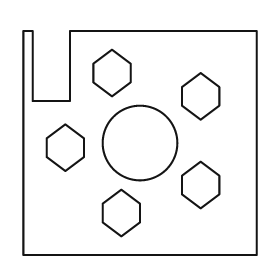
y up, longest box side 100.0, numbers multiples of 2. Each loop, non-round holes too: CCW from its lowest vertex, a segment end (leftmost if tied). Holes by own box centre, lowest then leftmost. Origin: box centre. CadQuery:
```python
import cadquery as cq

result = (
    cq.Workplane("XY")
    .moveTo(-50.0, -48.0)
    .lineTo(50.0, -48.0)
    .lineTo(50.0, 48.0)
    .lineTo(-30.0, 48.0)
    .lineTo(-30.0, 18.0)
    .lineTo(-46.0, 18.0)
    .lineTo(-46.0, 48.0)
    .lineTo(-50.0, 48.0)
    .close()
    .moveTo(-8.0, -40.0)
    .lineTo(0.0, -34.0)
    .lineTo(0.0, -26.0)
    .lineTo(-8.0, -20.0)
    .lineTo(-16.0, -26.0)
    .lineTo(-16.0, -34.0)
    .close()
    .moveTo(26.0, -28.0)
    .lineTo(34.0, -22.0)
    .lineTo(34.0, -14.0)
    .lineTo(26.0, -8.0)
    .lineTo(18.0, -14.0)
    .lineTo(18.0, -22.0)
    .close()
    .moveTo(-32.0, -12.0)
    .lineTo(-24.0, -6.0)
    .lineTo(-24.0, 2.0)
    .lineTo(-32.0, 8.0)
    .lineTo(-40.0, 2.0)
    .lineTo(-40.0, -6.0)
    .close()
    .moveTo(0.0, 0.0)
    .circle(16.0)
    .moveTo(26.0, 10.0)
    .lineTo(34.0, 16.0)
    .lineTo(34.0, 24.0)
    .lineTo(26.0, 30.0)
    .lineTo(18.0, 24.0)
    .lineTo(18.0, 16.0)
    .close()
    .moveTo(-12.0, 20.0)
    .lineTo(-4.0, 26.0)
    .lineTo(-4.0, 34.0)
    .lineTo(-12.0, 40.0)
    .lineTo(-20.0, 34.0)
    .lineTo(-20.0, 26.0)
    .close()
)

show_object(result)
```